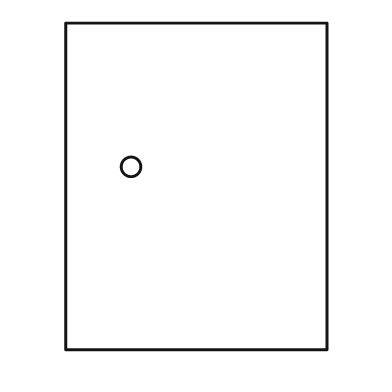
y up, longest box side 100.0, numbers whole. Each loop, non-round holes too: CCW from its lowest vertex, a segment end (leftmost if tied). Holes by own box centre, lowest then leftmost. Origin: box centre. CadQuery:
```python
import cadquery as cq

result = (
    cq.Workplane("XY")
    .moveTo(-40.0, -50.0)
    .lineTo(40.0, -50.0)
    .lineTo(40.0, 50.0)
    .lineTo(-40.0, 50.0)
    .close()
    .moveTo(-20.0, 6.0)
    .circle(3.0)
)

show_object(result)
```